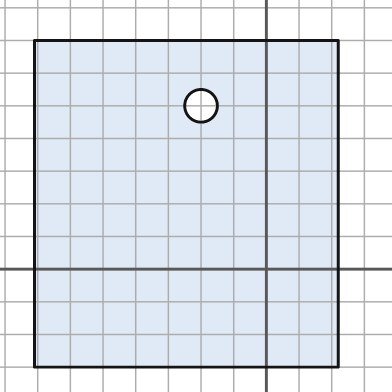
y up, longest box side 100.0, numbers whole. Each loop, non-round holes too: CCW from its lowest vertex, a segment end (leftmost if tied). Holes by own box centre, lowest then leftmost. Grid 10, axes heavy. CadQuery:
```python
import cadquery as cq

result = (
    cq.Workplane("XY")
    .moveTo(-71.0, -30.0)
    .lineTo(22.0, -30.0)
    .lineTo(22.0, 70.0)
    .lineTo(-71.0, 70.0)
    .close()
    .moveTo(-20.0, 50.0)
    .circle(5.0)
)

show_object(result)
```